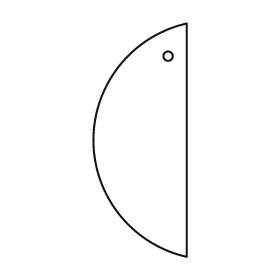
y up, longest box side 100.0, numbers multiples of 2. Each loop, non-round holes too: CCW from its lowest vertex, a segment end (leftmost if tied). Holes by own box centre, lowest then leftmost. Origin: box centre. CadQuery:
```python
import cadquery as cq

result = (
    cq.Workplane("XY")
    .moveTo(20.0, -50.0)
    .lineTo(20.0, 50.0)
    .threePointArc((-20.0, 0.0), (20.0, -50.0))
    .close()
    .moveTo(12.0, 36.0)
    .circle(2.0)
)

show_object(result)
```